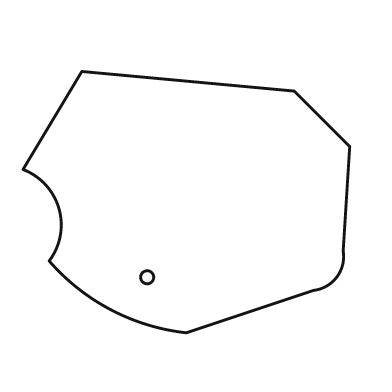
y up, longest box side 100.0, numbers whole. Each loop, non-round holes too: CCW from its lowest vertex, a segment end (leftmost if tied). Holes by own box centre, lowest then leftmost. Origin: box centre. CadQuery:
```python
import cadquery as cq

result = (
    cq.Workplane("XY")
    .moveTo(0.0, -40.0)
    .lineTo(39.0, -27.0)
    .threePointArc((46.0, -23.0), (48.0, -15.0))
    .lineTo(50.0, 17.0)
    .lineTo(33.0, 34.0)
    .lineTo(-32.0, 40.0)
    .lineTo(-50.0, 10.0)
    .threePointArc((-39.0, -2.0), (-42.0, -18.0))
    .threePointArc((-23.0, -33.0), (0.0, -40.0))
    .close()
    .moveTo(-12.0, -23.0)
    .circle(2.0)
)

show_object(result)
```